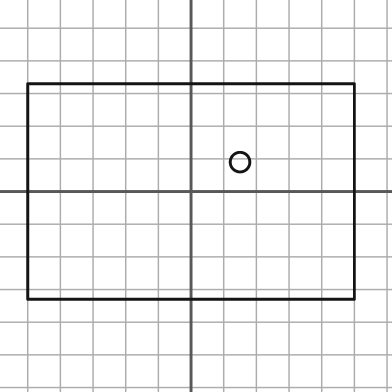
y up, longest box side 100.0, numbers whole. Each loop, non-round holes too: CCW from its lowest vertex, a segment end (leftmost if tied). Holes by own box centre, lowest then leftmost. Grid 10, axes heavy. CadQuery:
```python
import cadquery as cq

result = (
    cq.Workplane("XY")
    .moveTo(-50.0, -33.0)
    .lineTo(50.0, -33.0)
    .lineTo(50.0, 33.0)
    .lineTo(-50.0, 33.0)
    .close()
    .moveTo(15.0, 9.0)
    .circle(3.0)
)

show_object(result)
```